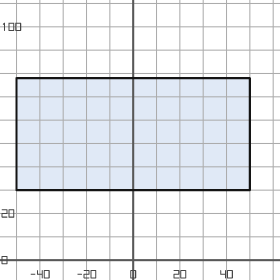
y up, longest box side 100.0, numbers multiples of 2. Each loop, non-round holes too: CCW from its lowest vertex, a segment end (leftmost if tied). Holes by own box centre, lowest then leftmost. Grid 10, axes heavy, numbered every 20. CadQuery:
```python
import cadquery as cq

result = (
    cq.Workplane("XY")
    .moveTo(-50.0, 30.0)
    .lineTo(50.0, 30.0)
    .lineTo(50.0, 78.0)
    .lineTo(-50.0, 78.0)
    .close()
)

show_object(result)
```